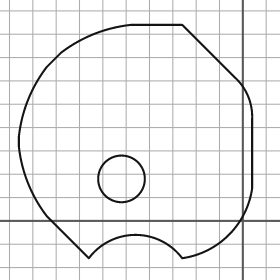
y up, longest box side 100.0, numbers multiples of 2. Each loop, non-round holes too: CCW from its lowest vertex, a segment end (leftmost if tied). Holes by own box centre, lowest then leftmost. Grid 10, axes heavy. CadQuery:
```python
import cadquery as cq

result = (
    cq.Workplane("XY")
    .moveTo(-66.0, -16.0)
    .threePointArc((-46.0, -6.0), (-26.0, -16.0))
    .threePointArc((-6.0, -6.0), (4.0, 14.0))
    .lineTo(4.0, 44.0)
    .threePointArc((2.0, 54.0), (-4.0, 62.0))
    .lineTo(-26.0, 84.0)
    .lineTo(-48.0, 84.0)
    .threePointArc((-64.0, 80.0), (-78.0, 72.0))
    .lineTo(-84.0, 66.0)
    .threePointArc((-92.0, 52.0), (-96.0, 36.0))
    .lineTo(-96.0, 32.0)
    .threePointArc((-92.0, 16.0), (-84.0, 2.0))
    .close()
    .moveTo(-52.0, 18.0)
    .circle(10.0)
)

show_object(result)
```